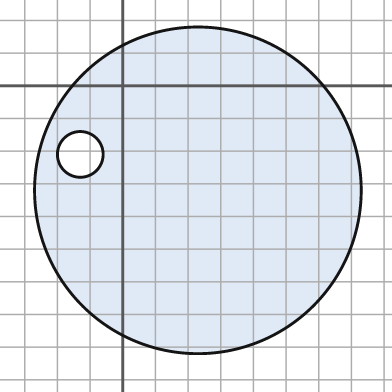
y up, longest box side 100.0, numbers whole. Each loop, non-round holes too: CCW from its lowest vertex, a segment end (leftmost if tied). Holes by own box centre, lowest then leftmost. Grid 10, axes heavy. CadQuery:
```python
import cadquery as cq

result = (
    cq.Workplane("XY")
    .moveTo(23.0, -32.0)
    .circle(50.0)
    .moveTo(-13.0, -21.0)
    .circle(7.0)
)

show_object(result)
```